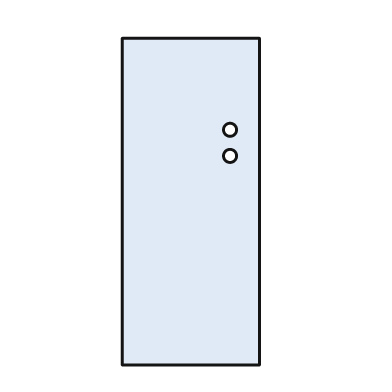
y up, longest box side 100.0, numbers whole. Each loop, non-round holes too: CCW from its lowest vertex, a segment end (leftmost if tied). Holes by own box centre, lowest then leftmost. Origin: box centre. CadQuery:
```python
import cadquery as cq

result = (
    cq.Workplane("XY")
    .moveTo(-21.0, -50.0)
    .lineTo(21.0, -50.0)
    .lineTo(21.0, 50.0)
    .lineTo(-21.0, 50.0)
    .close()
    .moveTo(12.0, 14.0)
    .circle(2.0)
    .moveTo(12.0, 22.0)
    .circle(2.0)
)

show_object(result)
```